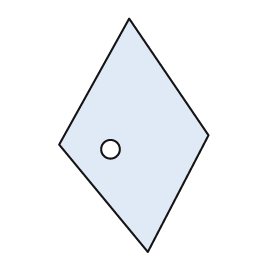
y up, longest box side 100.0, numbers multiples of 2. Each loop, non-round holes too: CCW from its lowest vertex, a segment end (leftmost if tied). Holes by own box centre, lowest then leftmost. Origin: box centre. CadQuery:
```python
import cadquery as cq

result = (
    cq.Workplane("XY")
    .moveTo(6.0, -50.0)
    .lineTo(32.0, 0.0)
    .lineTo(-2.0, 50.0)
    .lineTo(-32.0, -4.0)
    .close()
    .moveTo(-10.0, -6.0)
    .circle(4.0)
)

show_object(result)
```